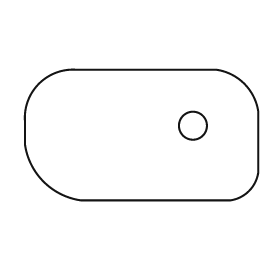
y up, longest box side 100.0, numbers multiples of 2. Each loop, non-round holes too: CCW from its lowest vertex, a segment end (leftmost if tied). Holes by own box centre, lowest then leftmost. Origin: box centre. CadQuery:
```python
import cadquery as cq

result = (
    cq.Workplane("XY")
    .moveTo(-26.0, -28.0)
    .lineTo(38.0, -28.0)
    .threePointArc((46.0, -24.0), (50.0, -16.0))
    .lineTo(50.0, 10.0)
    .threePointArc((44.0, 22.0), (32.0, 28.0))
    .lineTo(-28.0, 28.0)
    .threePointArc((-44.0, 22.0), (-50.0, 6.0))
    .lineTo(-50.0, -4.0)
    .threePointArc((-42.0, -20.0), (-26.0, -28.0))
    .close()
    .moveTo(22.0, 4.0)
    .circle(6.0)
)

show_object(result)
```